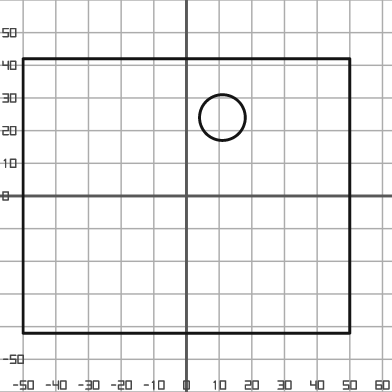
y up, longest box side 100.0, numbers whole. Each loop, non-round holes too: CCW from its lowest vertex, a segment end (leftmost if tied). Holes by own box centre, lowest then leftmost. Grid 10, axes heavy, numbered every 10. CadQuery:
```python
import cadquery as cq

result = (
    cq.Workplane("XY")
    .moveTo(-50.0, -42.0)
    .lineTo(50.0, -42.0)
    .lineTo(50.0, 42.0)
    .lineTo(-50.0, 42.0)
    .close()
    .moveTo(11.0, 24.0)
    .circle(7.0)
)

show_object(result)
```